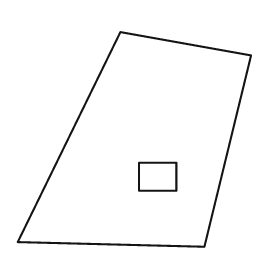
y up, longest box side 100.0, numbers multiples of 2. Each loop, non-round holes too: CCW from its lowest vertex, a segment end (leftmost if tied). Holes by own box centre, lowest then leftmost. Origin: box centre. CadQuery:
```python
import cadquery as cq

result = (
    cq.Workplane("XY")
    .moveTo(30.0, -46.0)
    .lineTo(50.0, 36.0)
    .lineTo(-6.0, 46.0)
    .lineTo(-50.0, -44.0)
    .close()
    .moveTo(2.0, -22.0)
    .lineTo(18.0, -22.0)
    .lineTo(18.0, -10.0)
    .lineTo(2.0, -10.0)
    .close()
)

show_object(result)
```